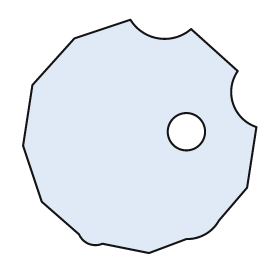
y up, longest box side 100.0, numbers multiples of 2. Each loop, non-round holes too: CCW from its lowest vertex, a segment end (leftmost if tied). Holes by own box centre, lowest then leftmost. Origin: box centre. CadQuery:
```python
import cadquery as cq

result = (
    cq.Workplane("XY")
    .moveTo(4.0, -50.0)
    .lineTo(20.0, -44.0)
    .threePointArc((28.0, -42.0), (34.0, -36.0))
    .lineTo(46.0, -22.0)
    .lineTo(50.0, 4.0)
    .threePointArc((40.0, 14.0), (42.0, 28.0))
    .lineTo(22.0, 46.0)
    .threePointArc((8.0, 42.0), (-4.0, 50.0))
    .lineTo(-28.0, 42.0)
    .lineTo(-46.0, 22.0)
    .lineTo(-50.0, -4.0)
    .lineTo(-42.0, -28.0)
    .lineTo(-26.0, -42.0)
    .threePointArc((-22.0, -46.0), (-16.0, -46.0))
    .close()
    .moveTo(20.0, 2.0)
    .circle(8.0)
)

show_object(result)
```